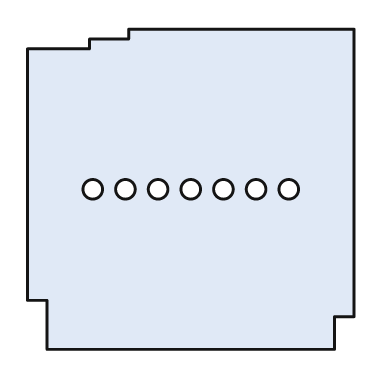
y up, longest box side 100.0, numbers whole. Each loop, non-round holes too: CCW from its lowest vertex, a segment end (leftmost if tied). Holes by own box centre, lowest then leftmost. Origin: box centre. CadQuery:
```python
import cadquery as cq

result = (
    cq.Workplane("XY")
    .moveTo(-44.0, -49.0)
    .lineTo(44.0, -49.0)
    .lineTo(44.0, -39.0)
    .lineTo(50.0, -39.0)
    .lineTo(50.0, 49.0)
    .lineTo(-19.0, 49.0)
    .lineTo(-19.0, 46.0)
    .lineTo(-31.0, 46.0)
    .lineTo(-31.0, 43.0)
    .lineTo(-50.0, 43.0)
    .lineTo(-50.0, -34.0)
    .lineTo(-44.0, -34.0)
    .close()
    .moveTo(-30.0, 0.0)
    .circle(3.0)
    .moveTo(-20.0, 0.0)
    .circle(3.0)
    .moveTo(-10.0, 0.0)
    .circle(3.0)
    .moveTo(0.0, 0.0)
    .circle(3.0)
    .moveTo(10.0, 0.0)
    .circle(3.0)
    .moveTo(20.0, 0.0)
    .circle(3.0)
    .moveTo(30.0, 0.0)
    .circle(3.0)
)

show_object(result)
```